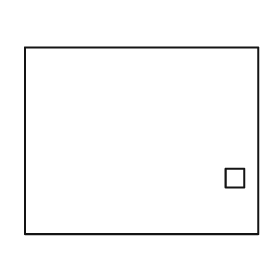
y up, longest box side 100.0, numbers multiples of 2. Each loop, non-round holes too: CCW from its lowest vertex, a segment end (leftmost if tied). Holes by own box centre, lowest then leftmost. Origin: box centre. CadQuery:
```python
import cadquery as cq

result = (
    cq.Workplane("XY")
    .moveTo(-50.0, -40.0)
    .lineTo(50.0, -40.0)
    .lineTo(50.0, 40.0)
    .lineTo(-50.0, 40.0)
    .close()
    .moveTo(36.0, -20.0)
    .lineTo(44.0, -20.0)
    .lineTo(44.0, -12.0)
    .lineTo(36.0, -12.0)
    .close()
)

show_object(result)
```